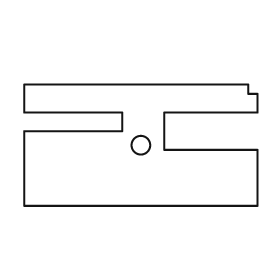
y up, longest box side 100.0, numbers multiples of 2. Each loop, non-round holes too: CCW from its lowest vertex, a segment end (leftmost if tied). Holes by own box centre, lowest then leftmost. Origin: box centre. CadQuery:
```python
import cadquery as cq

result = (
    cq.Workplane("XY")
    .moveTo(-50.0, -26.0)
    .lineTo(50.0, -26.0)
    .lineTo(50.0, -2.0)
    .lineTo(10.0, -2.0)
    .lineTo(10.0, 14.0)
    .lineTo(50.0, 14.0)
    .lineTo(50.0, 22.0)
    .lineTo(46.0, 22.0)
    .lineTo(46.0, 26.0)
    .lineTo(-50.0, 26.0)
    .lineTo(-50.0, 14.0)
    .lineTo(-8.0, 14.0)
    .lineTo(-8.0, 6.0)
    .lineTo(-50.0, 6.0)
    .close()
    .moveTo(0.0, 0.0)
    .circle(4.0)
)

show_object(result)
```